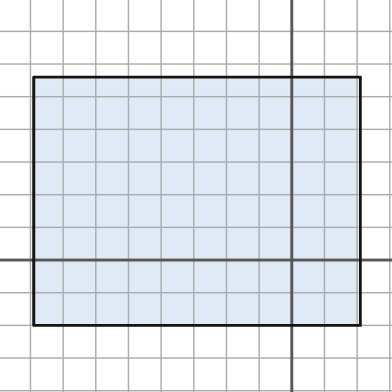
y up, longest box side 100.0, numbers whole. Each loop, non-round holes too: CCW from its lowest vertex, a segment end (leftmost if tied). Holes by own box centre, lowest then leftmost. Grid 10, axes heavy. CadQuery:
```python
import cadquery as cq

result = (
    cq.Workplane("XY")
    .moveTo(-79.0, -20.0)
    .lineTo(21.0, -20.0)
    .lineTo(21.0, 56.0)
    .lineTo(-79.0, 56.0)
    .close()
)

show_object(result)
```